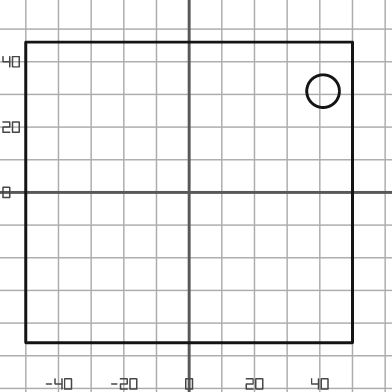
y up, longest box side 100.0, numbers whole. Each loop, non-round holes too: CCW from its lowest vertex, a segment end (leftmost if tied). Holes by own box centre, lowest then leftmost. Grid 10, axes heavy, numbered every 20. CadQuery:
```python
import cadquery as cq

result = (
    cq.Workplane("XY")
    .moveTo(-50.0, -46.0)
    .lineTo(50.0, -46.0)
    .lineTo(50.0, 46.0)
    .lineTo(-50.0, 46.0)
    .close()
    .moveTo(41.0, 31.0)
    .circle(5.0)
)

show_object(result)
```